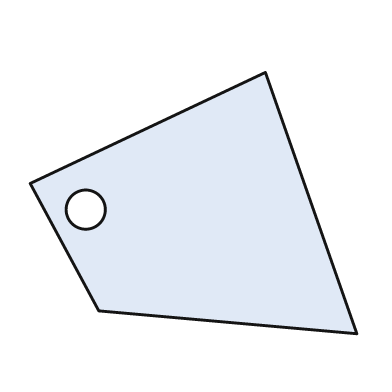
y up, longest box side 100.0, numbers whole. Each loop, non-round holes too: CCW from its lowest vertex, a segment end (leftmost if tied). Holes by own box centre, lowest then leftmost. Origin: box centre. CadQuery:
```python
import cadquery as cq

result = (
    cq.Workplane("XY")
    .moveTo(50.0, -40.0)
    .lineTo(22.0, 40.0)
    .lineTo(-50.0, 6.0)
    .lineTo(-29.0, -33.0)
    .close()
    .moveTo(-33.0, -2.0)
    .circle(6.0)
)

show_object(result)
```